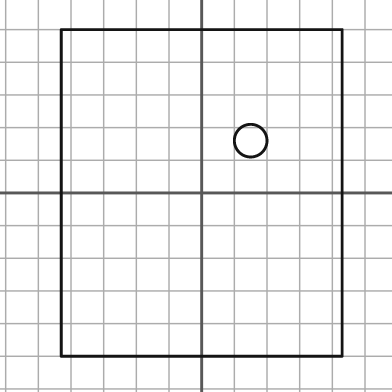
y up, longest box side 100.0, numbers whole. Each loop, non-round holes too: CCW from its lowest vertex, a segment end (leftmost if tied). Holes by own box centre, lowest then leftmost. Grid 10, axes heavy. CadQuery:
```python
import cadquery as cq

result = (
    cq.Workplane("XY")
    .moveTo(-43.0, -50.0)
    .lineTo(43.0, -50.0)
    .lineTo(43.0, 50.0)
    .lineTo(-43.0, 50.0)
    .close()
    .moveTo(15.0, 16.0)
    .circle(5.0)
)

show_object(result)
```